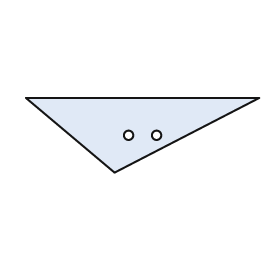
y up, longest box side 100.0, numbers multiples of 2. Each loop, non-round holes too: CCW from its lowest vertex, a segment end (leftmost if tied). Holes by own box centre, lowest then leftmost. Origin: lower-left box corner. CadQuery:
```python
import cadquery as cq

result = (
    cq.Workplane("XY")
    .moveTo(38.0, 0.0)
    .lineTo(100.0, 32.0)
    .lineTo(0.0, 32.0)
    .close()
    .moveTo(44.0, 16.0)
    .circle(2.0)
    .moveTo(56.0, 16.0)
    .circle(2.0)
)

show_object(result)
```